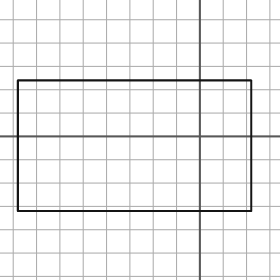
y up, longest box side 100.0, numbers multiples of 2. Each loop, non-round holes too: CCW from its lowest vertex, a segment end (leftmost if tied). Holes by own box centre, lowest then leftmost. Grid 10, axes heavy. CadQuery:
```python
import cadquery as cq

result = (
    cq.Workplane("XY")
    .moveTo(-78.0, -32.0)
    .lineTo(22.0, -32.0)
    .lineTo(22.0, 24.0)
    .lineTo(-78.0, 24.0)
    .close()
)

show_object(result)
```